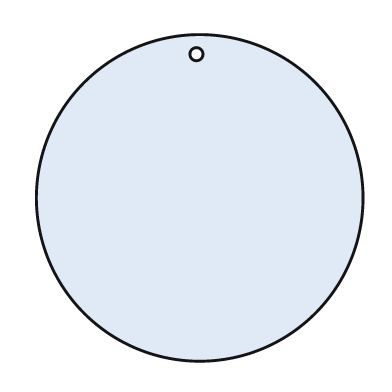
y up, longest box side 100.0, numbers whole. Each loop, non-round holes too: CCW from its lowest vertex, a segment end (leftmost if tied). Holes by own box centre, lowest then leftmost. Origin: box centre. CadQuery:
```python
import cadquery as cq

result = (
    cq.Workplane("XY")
    .moveTo(0.0, 0.0)
    .circle(50.0)
    .moveTo(-1.0, 44.0)
    .circle(2.0)
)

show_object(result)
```